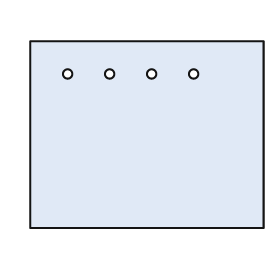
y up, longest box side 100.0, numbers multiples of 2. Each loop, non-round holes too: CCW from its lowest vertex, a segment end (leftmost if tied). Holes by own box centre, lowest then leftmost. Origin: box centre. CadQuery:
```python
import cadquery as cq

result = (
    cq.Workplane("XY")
    .moveTo(-50.0, -40.0)
    .lineTo(50.0, -40.0)
    .lineTo(50.0, 40.0)
    .lineTo(-50.0, 40.0)
    .close()
    .moveTo(-34.0, 26.0)
    .circle(2.0)
    .moveTo(-16.0, 26.0)
    .circle(2.0)
    .moveTo(2.0, 26.0)
    .circle(2.0)
    .moveTo(20.0, 26.0)
    .circle(2.0)
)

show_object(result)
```